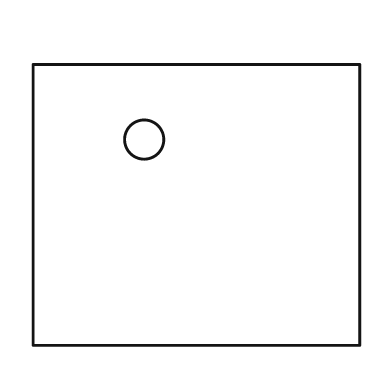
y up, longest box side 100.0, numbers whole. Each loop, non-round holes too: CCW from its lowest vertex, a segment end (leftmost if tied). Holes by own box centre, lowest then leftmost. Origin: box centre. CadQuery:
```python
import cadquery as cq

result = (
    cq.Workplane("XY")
    .moveTo(-50.0, -43.0)
    .lineTo(50.0, -43.0)
    .lineTo(50.0, 43.0)
    .lineTo(-50.0, 43.0)
    .close()
    .moveTo(-16.0, 20.0)
    .circle(6.0)
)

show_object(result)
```